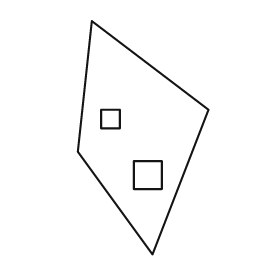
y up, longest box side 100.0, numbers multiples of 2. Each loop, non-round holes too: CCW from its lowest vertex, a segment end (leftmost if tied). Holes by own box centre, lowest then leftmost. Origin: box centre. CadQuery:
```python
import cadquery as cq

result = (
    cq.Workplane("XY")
    .moveTo(4.0, -50.0)
    .lineTo(28.0, 12.0)
    .lineTo(-22.0, 50.0)
    .lineTo(-28.0, -6.0)
    .close()
    .moveTo(-4.0, -22.0)
    .lineTo(8.0, -22.0)
    .lineTo(8.0, -10.0)
    .lineTo(-4.0, -10.0)
    .close()
    .moveTo(-18.0, 4.0)
    .lineTo(-10.0, 4.0)
    .lineTo(-10.0, 12.0)
    .lineTo(-18.0, 12.0)
    .close()
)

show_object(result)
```